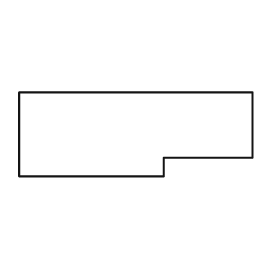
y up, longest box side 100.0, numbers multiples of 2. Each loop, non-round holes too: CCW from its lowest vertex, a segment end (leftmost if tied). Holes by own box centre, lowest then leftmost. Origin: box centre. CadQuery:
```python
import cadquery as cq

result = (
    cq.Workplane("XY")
    .moveTo(-50.0, -18.0)
    .lineTo(12.0, -18.0)
    .lineTo(12.0, -10.0)
    .lineTo(50.0, -10.0)
    .lineTo(50.0, 18.0)
    .lineTo(-50.0, 18.0)
    .close()
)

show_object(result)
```